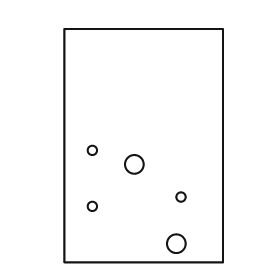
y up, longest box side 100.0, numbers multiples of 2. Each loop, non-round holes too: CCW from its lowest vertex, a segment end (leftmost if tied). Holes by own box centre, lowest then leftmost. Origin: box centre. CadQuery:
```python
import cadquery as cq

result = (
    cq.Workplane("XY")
    .moveTo(-34.0, -50.0)
    .lineTo(34.0, -50.0)
    .lineTo(34.0, 50.0)
    .lineTo(-34.0, 50.0)
    .close()
    .moveTo(14.0, -42.0)
    .circle(4.0)
    .moveTo(-22.0, -26.0)
    .circle(2.0)
    .moveTo(16.0, -22.0)
    .circle(2.0)
    .moveTo(-4.0, -8.0)
    .circle(4.0)
    .moveTo(-22.0, -2.0)
    .circle(2.0)
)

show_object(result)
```